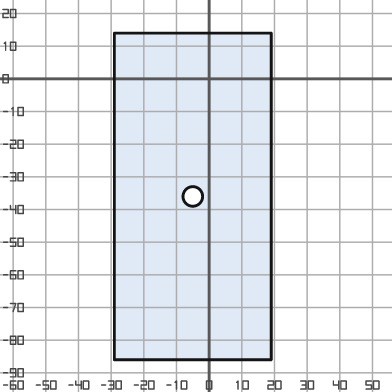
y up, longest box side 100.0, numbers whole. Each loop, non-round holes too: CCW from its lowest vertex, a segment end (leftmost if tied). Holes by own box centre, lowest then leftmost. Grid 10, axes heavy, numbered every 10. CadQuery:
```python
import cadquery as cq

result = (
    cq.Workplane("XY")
    .moveTo(-29.0, -86.0)
    .lineTo(19.0, -86.0)
    .lineTo(19.0, 14.0)
    .lineTo(-29.0, 14.0)
    .close()
    .moveTo(-5.0, -36.0)
    .circle(3.0)
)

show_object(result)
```